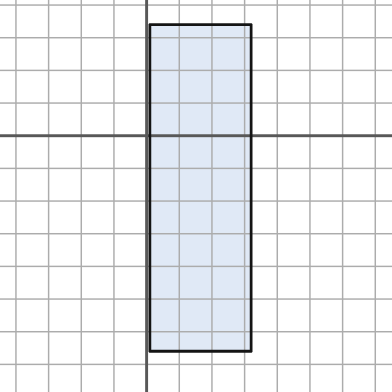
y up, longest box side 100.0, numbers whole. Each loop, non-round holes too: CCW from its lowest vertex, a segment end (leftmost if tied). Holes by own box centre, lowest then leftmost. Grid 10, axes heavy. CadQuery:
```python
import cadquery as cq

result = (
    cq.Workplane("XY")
    .moveTo(1.0, -66.0)
    .lineTo(32.0, -66.0)
    .lineTo(32.0, 34.0)
    .lineTo(1.0, 34.0)
    .close()
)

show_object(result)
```